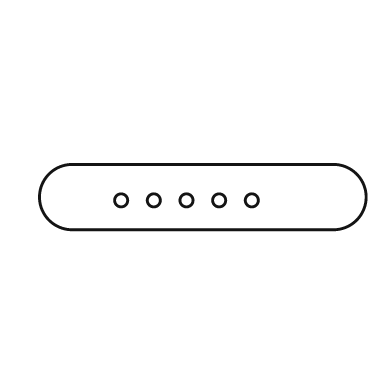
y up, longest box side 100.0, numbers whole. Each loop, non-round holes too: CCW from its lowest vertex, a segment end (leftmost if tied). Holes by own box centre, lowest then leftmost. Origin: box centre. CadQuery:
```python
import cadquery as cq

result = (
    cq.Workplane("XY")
    .moveTo(-40.0, -10.0)
    .lineTo(40.0, -10.0)
    .threePointArc((50.0, 0.0), (40.0, 10.0))
    .lineTo(-40.0, 10.0)
    .threePointArc((-50.0, 0.0), (-40.0, -10.0))
    .close()
    .moveTo(-25.0, -1.0)
    .circle(2.0)
    .moveTo(-15.0, -1.0)
    .circle(2.0)
    .moveTo(-5.0, -1.0)
    .circle(2.0)
    .moveTo(5.0, -1.0)
    .circle(2.0)
    .moveTo(15.0, -1.0)
    .circle(2.0)
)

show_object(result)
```